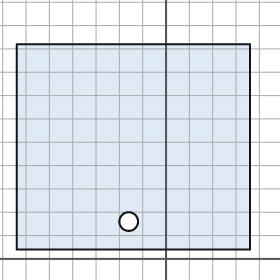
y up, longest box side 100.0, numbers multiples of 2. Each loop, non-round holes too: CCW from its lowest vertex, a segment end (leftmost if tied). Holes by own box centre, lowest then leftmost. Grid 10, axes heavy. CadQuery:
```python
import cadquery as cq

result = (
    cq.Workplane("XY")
    .moveTo(-64.0, 4.0)
    .lineTo(36.0, 4.0)
    .lineTo(36.0, 92.0)
    .lineTo(-64.0, 92.0)
    .close()
    .moveTo(-16.0, 16.0)
    .circle(4.0)
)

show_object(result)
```